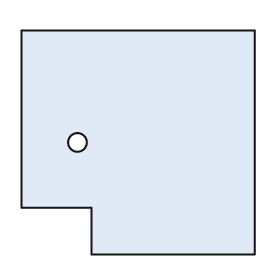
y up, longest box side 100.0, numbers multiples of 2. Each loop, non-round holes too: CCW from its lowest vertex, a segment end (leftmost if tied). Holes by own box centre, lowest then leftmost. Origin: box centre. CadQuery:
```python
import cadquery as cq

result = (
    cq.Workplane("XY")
    .moveTo(-20.0, -48.0)
    .lineTo(50.0, -48.0)
    .lineTo(50.0, 48.0)
    .lineTo(-50.0, 48.0)
    .lineTo(-50.0, -28.0)
    .lineTo(-20.0, -28.0)
    .close()
    .moveTo(-26.0, 0.0)
    .circle(4.0)
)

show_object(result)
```